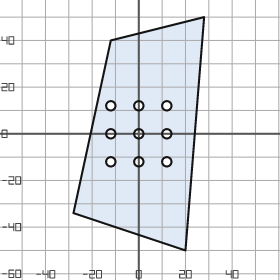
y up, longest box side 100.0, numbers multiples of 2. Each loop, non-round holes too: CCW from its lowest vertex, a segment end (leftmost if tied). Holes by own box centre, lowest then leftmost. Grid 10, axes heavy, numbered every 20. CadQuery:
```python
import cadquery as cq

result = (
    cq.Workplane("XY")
    .moveTo(20.0, -50.0)
    .lineTo(28.0, 50.0)
    .lineTo(-12.0, 40.0)
    .lineTo(-28.0, -34.0)
    .close()
    .moveTo(-12.0, -12.0)
    .circle(2.0)
    .moveTo(0.0, -12.0)
    .circle(2.0)
    .moveTo(12.0, -12.0)
    .circle(2.0)
    .moveTo(-12.0, 0.0)
    .circle(2.0)
    .moveTo(0.0, 0.0)
    .circle(2.0)
    .moveTo(12.0, 0.0)
    .circle(2.0)
    .moveTo(-12.0, 12.0)
    .circle(2.0)
    .moveTo(0.0, 12.0)
    .circle(2.0)
    .moveTo(12.0, 12.0)
    .circle(2.0)
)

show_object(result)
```